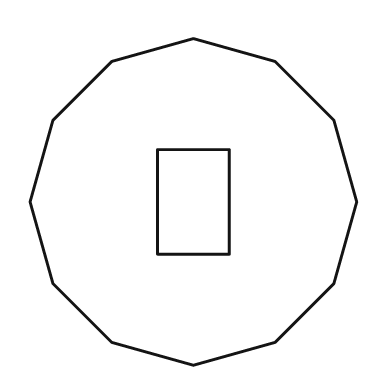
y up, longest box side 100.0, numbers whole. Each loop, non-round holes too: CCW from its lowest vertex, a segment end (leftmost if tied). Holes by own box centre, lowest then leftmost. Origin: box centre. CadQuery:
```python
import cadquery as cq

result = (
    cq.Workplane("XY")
    .moveTo(0.0, -50.0)
    .lineTo(25.0, -43.0)
    .lineTo(43.0, -25.0)
    .lineTo(50.0, 0.0)
    .lineTo(43.0, 25.0)
    .lineTo(25.0, 43.0)
    .lineTo(0.0, 50.0)
    .lineTo(-25.0, 43.0)
    .lineTo(-43.0, 25.0)
    .lineTo(-50.0, 0.0)
    .lineTo(-43.0, -25.0)
    .lineTo(-25.0, -43.0)
    .close()
    .moveTo(-11.0, -16.0)
    .lineTo(11.0, -16.0)
    .lineTo(11.0, 16.0)
    .lineTo(-11.0, 16.0)
    .close()
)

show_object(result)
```